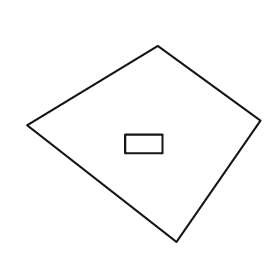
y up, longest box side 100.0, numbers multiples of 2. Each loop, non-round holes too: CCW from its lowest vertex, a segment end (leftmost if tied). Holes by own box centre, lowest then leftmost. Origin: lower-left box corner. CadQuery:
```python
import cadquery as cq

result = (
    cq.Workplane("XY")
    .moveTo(64.0, 0.0)
    .lineTo(100.0, 52.0)
    .lineTo(56.0, 84.0)
    .lineTo(0.0, 50.0)
    .close()
    .moveTo(42.0, 38.0)
    .lineTo(58.0, 38.0)
    .lineTo(58.0, 46.0)
    .lineTo(42.0, 46.0)
    .close()
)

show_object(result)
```